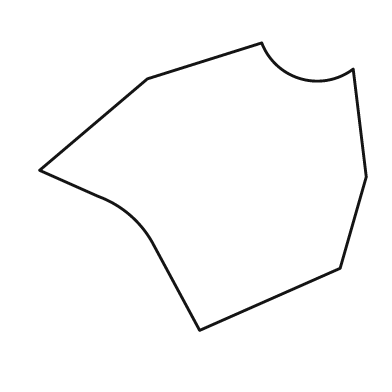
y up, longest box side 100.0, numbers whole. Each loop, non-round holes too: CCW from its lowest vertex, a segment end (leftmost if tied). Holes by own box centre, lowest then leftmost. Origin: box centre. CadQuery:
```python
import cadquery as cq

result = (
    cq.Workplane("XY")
    .moveTo(-1.0, -44.0)
    .lineTo(42.0, -25.0)
    .lineTo(50.0, 3.0)
    .lineTo(46.0, 36.0)
    .threePointArc((30.0, 33.0), (18.0, 44.0))
    .lineTo(-17.0, 33.0)
    .lineTo(-50.0, 5.0)
    .lineTo(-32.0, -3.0)
    .threePointArc((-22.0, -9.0), (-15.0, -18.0))
    .close()
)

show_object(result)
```